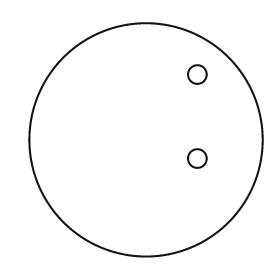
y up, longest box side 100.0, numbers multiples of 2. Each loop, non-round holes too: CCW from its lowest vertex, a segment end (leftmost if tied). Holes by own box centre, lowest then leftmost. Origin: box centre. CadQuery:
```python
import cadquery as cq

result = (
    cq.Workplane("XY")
    .moveTo(0.0, 0.0)
    .circle(50.0)
    .moveTo(22.0, -8.0)
    .circle(4.0)
    .moveTo(22.0, 28.0)
    .circle(4.0)
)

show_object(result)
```